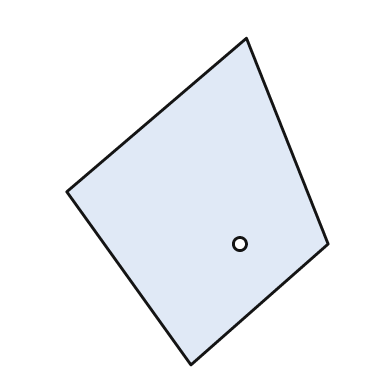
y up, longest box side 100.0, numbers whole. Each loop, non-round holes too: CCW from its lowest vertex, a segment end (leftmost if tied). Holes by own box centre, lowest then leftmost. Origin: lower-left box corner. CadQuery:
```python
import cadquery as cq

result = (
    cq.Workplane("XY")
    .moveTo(38.0, 0.0)
    .lineTo(80.0, 37.0)
    .lineTo(55.0, 100.0)
    .lineTo(0.0, 53.0)
    .close()
    .moveTo(53.0, 37.0)
    .circle(2.0)
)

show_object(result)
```